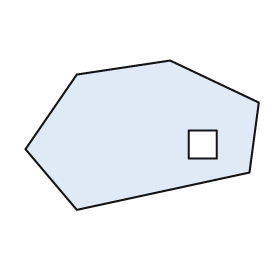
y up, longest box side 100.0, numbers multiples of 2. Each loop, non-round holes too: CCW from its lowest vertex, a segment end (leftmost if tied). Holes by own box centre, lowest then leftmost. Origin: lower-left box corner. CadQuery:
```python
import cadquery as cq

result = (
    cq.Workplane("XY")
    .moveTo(22.0, 0.0)
    .lineTo(96.0, 16.0)
    .lineTo(100.0, 46.0)
    .lineTo(62.0, 64.0)
    .lineTo(22.0, 58.0)
    .lineTo(0.0, 26.0)
    .close()
    .moveTo(70.0, 22.0)
    .lineTo(82.0, 22.0)
    .lineTo(82.0, 34.0)
    .lineTo(70.0, 34.0)
    .close()
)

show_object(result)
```